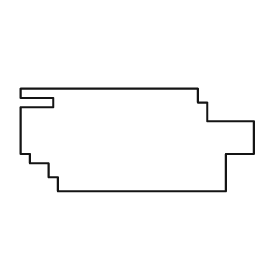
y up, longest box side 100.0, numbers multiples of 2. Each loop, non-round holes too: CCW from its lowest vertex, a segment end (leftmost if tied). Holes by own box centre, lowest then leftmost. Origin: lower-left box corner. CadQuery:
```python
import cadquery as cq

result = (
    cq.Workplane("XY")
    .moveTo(16.0, 0.0)
    .lineTo(88.0, 0.0)
    .lineTo(88.0, 16.0)
    .lineTo(100.0, 16.0)
    .lineTo(100.0, 30.0)
    .lineTo(80.0, 30.0)
    .lineTo(80.0, 38.0)
    .lineTo(76.0, 38.0)
    .lineTo(76.0, 44.0)
    .lineTo(0.0, 44.0)
    .lineTo(0.0, 40.0)
    .lineTo(14.0, 40.0)
    .lineTo(14.0, 36.0)
    .lineTo(0.0, 36.0)
    .lineTo(0.0, 16.0)
    .lineTo(4.0, 16.0)
    .lineTo(4.0, 12.0)
    .lineTo(12.0, 12.0)
    .lineTo(12.0, 6.0)
    .lineTo(16.0, 6.0)
    .close()
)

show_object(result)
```